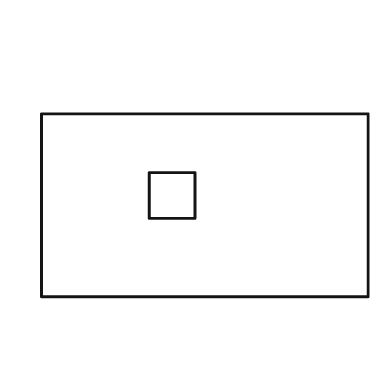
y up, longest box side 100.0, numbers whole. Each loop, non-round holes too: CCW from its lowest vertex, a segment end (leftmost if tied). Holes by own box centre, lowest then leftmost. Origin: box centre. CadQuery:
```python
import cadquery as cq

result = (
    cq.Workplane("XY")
    .moveTo(-50.0, -28.0)
    .lineTo(50.0, -28.0)
    .lineTo(50.0, 28.0)
    .lineTo(-50.0, 28.0)
    .close()
    .moveTo(-17.0, -4.0)
    .lineTo(-3.0, -4.0)
    .lineTo(-3.0, 10.0)
    .lineTo(-17.0, 10.0)
    .close()
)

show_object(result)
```